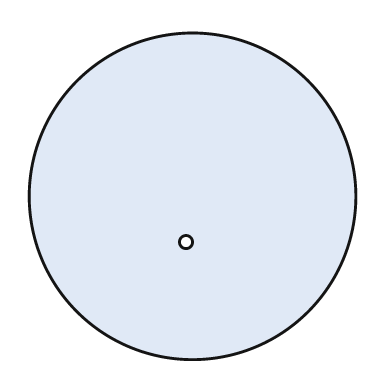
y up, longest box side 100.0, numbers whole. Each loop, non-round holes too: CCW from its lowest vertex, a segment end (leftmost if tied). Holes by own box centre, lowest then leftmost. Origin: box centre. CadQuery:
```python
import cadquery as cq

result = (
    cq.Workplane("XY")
    .moveTo(0.0, 0.0)
    .circle(50.0)
    .moveTo(-2.0, -14.0)
    .circle(2.0)
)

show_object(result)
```